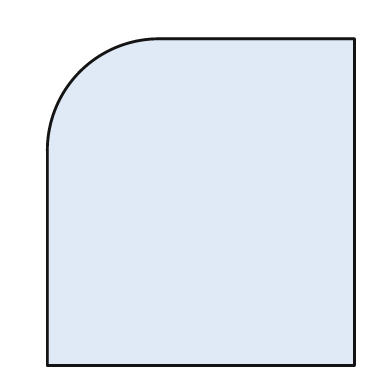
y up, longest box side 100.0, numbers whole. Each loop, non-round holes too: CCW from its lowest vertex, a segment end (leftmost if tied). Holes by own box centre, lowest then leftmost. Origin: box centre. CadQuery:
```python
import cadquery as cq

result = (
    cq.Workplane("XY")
    .moveTo(-47.0, -50.0)
    .lineTo(47.0, -50.0)
    .lineTo(47.0, 50.0)
    .lineTo(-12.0, 50.0)
    .threePointArc((-37.0, 40.0), (-47.0, 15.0))
    .close()
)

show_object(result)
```